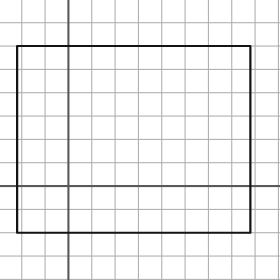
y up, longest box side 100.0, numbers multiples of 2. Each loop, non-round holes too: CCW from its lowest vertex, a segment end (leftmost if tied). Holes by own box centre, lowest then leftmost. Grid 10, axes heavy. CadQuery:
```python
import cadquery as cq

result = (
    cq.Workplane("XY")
    .moveTo(-22.0, -20.0)
    .lineTo(78.0, -20.0)
    .lineTo(78.0, 60.0)
    .lineTo(-22.0, 60.0)
    .close()
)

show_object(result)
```